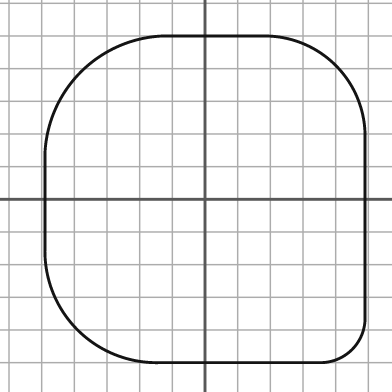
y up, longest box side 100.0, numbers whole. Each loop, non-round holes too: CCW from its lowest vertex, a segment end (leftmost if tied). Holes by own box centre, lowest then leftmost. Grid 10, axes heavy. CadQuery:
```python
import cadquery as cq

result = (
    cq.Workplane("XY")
    .moveTo(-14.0, -50.0)
    .lineTo(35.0, -50.0)
    .threePointArc((45.0, -46.0), (49.0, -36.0))
    .lineTo(49.0, 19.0)
    .threePointArc((40.0, 41.0), (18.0, 50.0))
    .lineTo(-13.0, 50.0)
    .threePointArc((-38.0, 39.0), (-49.0, 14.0))
    .lineTo(-49.0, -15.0)
    .threePointArc((-39.0, -40.0), (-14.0, -50.0))
    .close()
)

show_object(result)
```